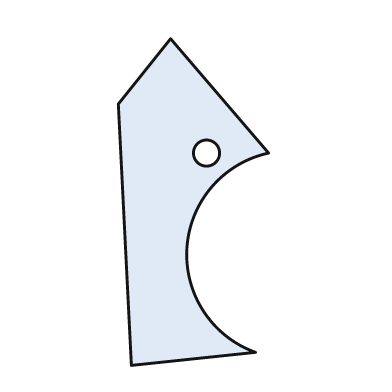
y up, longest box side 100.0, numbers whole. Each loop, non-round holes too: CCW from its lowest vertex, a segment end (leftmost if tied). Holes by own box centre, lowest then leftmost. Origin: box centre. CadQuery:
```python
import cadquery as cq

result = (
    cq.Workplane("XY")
    .moveTo(-19.0, -50.0)
    .lineTo(19.0, -46.0)
    .threePointArc((-2.0, -14.0), (23.0, 15.0))
    .lineTo(-7.0, 50.0)
    .lineTo(-23.0, 30.0)
    .close()
    .moveTo(4.0, 15.0)
    .circle(4.0)
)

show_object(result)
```